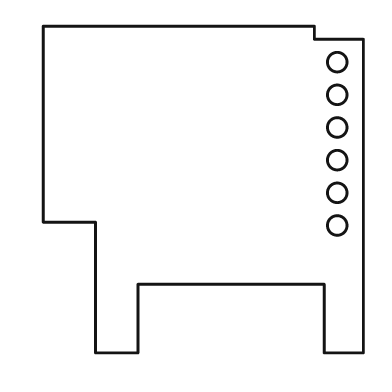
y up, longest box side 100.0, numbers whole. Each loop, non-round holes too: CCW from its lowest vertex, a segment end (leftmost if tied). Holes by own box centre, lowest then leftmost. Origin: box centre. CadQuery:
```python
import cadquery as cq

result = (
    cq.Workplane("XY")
    .moveTo(-33.0, -50.0)
    .lineTo(-20.0, -50.0)
    .lineTo(-20.0, -29.0)
    .lineTo(37.0, -29.0)
    .lineTo(37.0, -50.0)
    .lineTo(49.0, -50.0)
    .lineTo(49.0, 46.0)
    .lineTo(34.0, 46.0)
    .lineTo(34.0, 50.0)
    .lineTo(-49.0, 50.0)
    .lineTo(-49.0, -10.0)
    .lineTo(-33.0, -10.0)
    .close()
    .moveTo(41.0, -11.0)
    .circle(3.0)
    .moveTo(41.0, -1.0)
    .circle(3.0)
    .moveTo(41.0, 9.0)
    .circle(3.0)
    .moveTo(41.0, 19.0)
    .circle(3.0)
    .moveTo(41.0, 29.0)
    .circle(3.0)
    .moveTo(41.0, 39.0)
    .circle(3.0)
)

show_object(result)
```